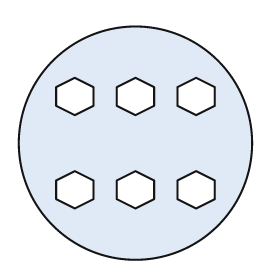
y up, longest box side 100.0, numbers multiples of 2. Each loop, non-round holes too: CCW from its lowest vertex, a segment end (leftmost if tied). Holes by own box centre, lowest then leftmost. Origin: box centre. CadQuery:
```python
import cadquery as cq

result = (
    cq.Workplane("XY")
    .moveTo(0.0, 0.0)
    .circle(50.0)
    .moveTo(-26.0, -28.0)
    .lineTo(-18.0, -24.0)
    .lineTo(-18.0, -16.0)
    .lineTo(-26.0, -12.0)
    .lineTo(-34.0, -16.0)
    .lineTo(-34.0, -24.0)
    .close()
    .moveTo(0.0, -28.0)
    .lineTo(8.0, -24.0)
    .lineTo(8.0, -16.0)
    .lineTo(0.0, -12.0)
    .lineTo(-8.0, -16.0)
    .lineTo(-8.0, -24.0)
    .close()
    .moveTo(26.0, -28.0)
    .lineTo(34.0, -24.0)
    .lineTo(34.0, -16.0)
    .lineTo(26.0, -12.0)
    .lineTo(18.0, -16.0)
    .lineTo(18.0, -24.0)
    .close()
    .moveTo(-26.0, 12.0)
    .lineTo(-18.0, 16.0)
    .lineTo(-18.0, 24.0)
    .lineTo(-26.0, 28.0)
    .lineTo(-34.0, 24.0)
    .lineTo(-34.0, 16.0)
    .close()
    .moveTo(0.0, 12.0)
    .lineTo(8.0, 16.0)
    .lineTo(8.0, 24.0)
    .lineTo(0.0, 28.0)
    .lineTo(-8.0, 24.0)
    .lineTo(-8.0, 16.0)
    .close()
    .moveTo(26.0, 12.0)
    .lineTo(34.0, 16.0)
    .lineTo(34.0, 24.0)
    .lineTo(26.0, 28.0)
    .lineTo(18.0, 24.0)
    .lineTo(18.0, 16.0)
    .close()
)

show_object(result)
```